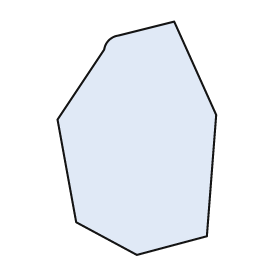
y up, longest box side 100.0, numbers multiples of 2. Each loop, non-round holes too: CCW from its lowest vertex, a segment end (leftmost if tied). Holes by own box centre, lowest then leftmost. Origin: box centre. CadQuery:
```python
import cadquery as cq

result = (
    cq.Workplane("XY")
    .moveTo(0.0, -50.0)
    .lineTo(30.0, -42.0)
    .lineTo(34.0, 10.0)
    .lineTo(16.0, 50.0)
    .lineTo(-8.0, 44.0)
    .threePointArc((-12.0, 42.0), (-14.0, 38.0))
    .lineTo(-34.0, 8.0)
    .lineTo(-26.0, -36.0)
    .close()
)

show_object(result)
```